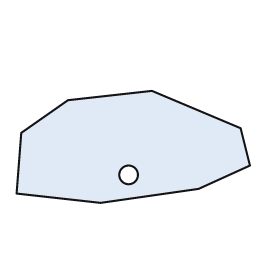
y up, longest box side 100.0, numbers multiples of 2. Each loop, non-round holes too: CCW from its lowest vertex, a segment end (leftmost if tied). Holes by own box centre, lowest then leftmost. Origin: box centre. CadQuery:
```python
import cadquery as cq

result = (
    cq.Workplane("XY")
    .moveTo(-14.0, -24.0)
    .lineTo(28.0, -18.0)
    .lineTo(50.0, -8.0)
    .lineTo(46.0, 8.0)
    .lineTo(8.0, 24.0)
    .lineTo(-28.0, 20.0)
    .lineTo(-48.0, 6.0)
    .lineTo(-50.0, -20.0)
    .close()
    .moveTo(-2.0, -12.0)
    .circle(4.0)
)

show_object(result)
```